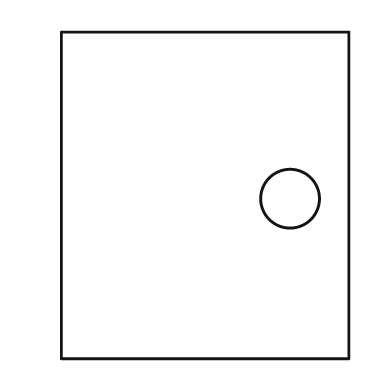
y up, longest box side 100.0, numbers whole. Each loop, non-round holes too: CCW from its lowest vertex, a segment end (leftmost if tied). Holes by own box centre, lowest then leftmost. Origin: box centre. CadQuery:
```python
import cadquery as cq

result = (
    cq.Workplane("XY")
    .moveTo(-44.0, -50.0)
    .lineTo(44.0, -50.0)
    .lineTo(44.0, 50.0)
    .lineTo(-44.0, 50.0)
    .close()
    .moveTo(26.0, -1.0)
    .circle(9.0)
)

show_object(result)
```